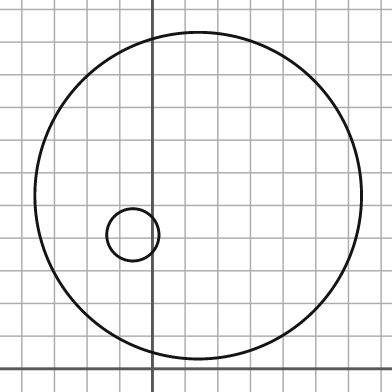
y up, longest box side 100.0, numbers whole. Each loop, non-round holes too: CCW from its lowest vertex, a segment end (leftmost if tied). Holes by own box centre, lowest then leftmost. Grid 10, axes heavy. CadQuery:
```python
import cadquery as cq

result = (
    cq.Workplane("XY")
    .moveTo(14.0, 53.0)
    .circle(50.0)
    .moveTo(-6.0, 41.0)
    .circle(8.0)
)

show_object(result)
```